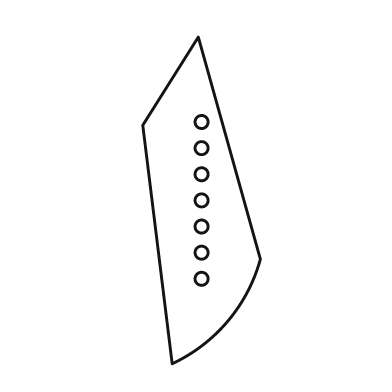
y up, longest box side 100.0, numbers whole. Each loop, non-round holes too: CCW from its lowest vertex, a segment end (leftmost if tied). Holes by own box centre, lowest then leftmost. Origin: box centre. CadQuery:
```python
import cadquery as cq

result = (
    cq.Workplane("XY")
    .moveTo(-9.0, -50.0)
    .threePointArc((8.0, -37.0), (18.0, -18.0))
    .lineTo(-1.0, 50.0)
    .lineTo(-18.0, 23.0)
    .close()
    .moveTo(0.0, -24.0)
    .circle(2.0)
    .moveTo(0.0, -16.0)
    .circle(2.0)
    .moveTo(0.0, -8.0)
    .circle(2.0)
    .moveTo(0.0, 0.0)
    .circle(2.0)
    .moveTo(0.0, 8.0)
    .circle(2.0)
    .moveTo(0.0, 16.0)
    .circle(2.0)
    .moveTo(0.0, 24.0)
    .circle(2.0)
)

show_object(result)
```